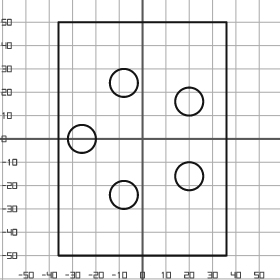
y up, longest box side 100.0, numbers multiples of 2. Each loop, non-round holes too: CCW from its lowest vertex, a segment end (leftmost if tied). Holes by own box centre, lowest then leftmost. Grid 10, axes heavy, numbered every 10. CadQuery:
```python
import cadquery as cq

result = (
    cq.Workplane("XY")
    .moveTo(-36.0, -50.0)
    .lineTo(36.0, -50.0)
    .lineTo(36.0, 50.0)
    .lineTo(-36.0, 50.0)
    .close()
    .moveTo(-8.0, -24.0)
    .circle(6.0)
    .moveTo(20.0, -16.0)
    .circle(6.0)
    .moveTo(-26.0, 0.0)
    .circle(6.0)
    .moveTo(20.0, 16.0)
    .circle(6.0)
    .moveTo(-8.0, 24.0)
    .circle(6.0)
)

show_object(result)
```